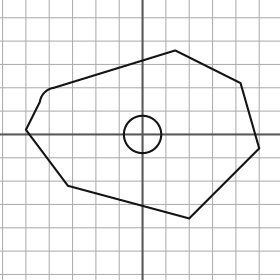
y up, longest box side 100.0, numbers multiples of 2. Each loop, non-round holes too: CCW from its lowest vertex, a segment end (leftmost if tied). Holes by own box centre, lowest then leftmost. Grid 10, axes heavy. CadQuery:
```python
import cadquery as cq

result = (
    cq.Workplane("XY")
    .moveTo(20.0, -36.0)
    .lineTo(50.0, -6.0)
    .lineTo(42.0, 22.0)
    .lineTo(14.0, 36.0)
    .lineTo(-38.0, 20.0)
    .threePointArc((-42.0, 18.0), (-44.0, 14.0))
    .lineTo(-50.0, 2.0)
    .lineTo(-32.0, -22.0)
    .close()
    .moveTo(0.0, 0.0)
    .circle(8.0)
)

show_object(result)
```